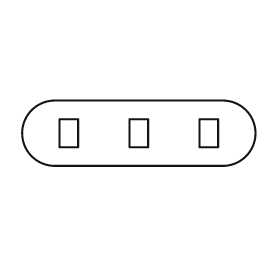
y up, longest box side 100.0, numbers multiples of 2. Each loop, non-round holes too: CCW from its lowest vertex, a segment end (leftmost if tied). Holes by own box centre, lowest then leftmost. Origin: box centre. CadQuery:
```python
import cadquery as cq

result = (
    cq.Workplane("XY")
    .moveTo(-36.0, -14.0)
    .lineTo(36.0, -14.0)
    .threePointArc((50.0, 0.0), (36.0, 14.0))
    .lineTo(-36.0, 14.0)
    .threePointArc((-50.0, 0.0), (-36.0, -14.0))
    .close()
    .moveTo(-34.0, -6.0)
    .lineTo(-26.0, -6.0)
    .lineTo(-26.0, 6.0)
    .lineTo(-34.0, 6.0)
    .close()
    .moveTo(-4.0, -6.0)
    .lineTo(4.0, -6.0)
    .lineTo(4.0, 6.0)
    .lineTo(-4.0, 6.0)
    .close()
    .moveTo(26.0, -6.0)
    .lineTo(34.0, -6.0)
    .lineTo(34.0, 6.0)
    .lineTo(26.0, 6.0)
    .close()
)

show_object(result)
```